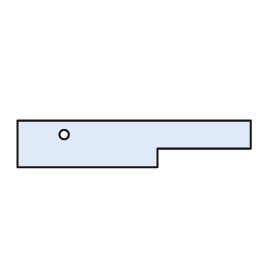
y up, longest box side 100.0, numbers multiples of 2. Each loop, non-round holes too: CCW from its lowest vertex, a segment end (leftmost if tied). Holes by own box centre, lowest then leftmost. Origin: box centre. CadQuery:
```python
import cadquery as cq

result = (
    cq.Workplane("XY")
    .moveTo(-50.0, -10.0)
    .lineTo(10.0, -10.0)
    .lineTo(10.0, -2.0)
    .lineTo(50.0, -2.0)
    .lineTo(50.0, 10.0)
    .lineTo(-50.0, 10.0)
    .close()
    .moveTo(-30.0, 4.0)
    .circle(2.0)
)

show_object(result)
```